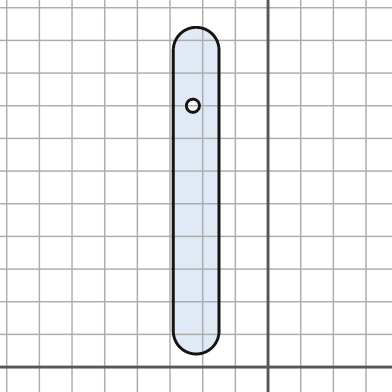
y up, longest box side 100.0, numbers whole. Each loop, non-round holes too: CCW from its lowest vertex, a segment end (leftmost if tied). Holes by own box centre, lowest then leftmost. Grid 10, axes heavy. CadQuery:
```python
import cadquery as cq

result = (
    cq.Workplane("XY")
    .moveTo(-29.0, 11.0)
    .threePointArc((-22.0, 4.0), (-15.0, 11.0))
    .lineTo(-15.0, 97.0)
    .threePointArc((-22.0, 104.0), (-29.0, 97.0))
    .close()
    .moveTo(-23.0, 80.0)
    .circle(2.0)
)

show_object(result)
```